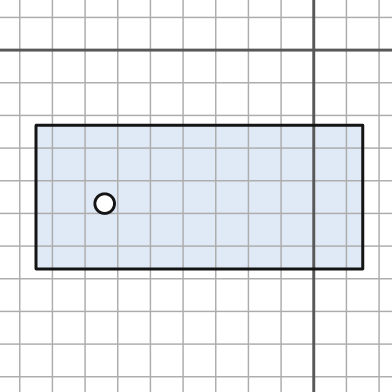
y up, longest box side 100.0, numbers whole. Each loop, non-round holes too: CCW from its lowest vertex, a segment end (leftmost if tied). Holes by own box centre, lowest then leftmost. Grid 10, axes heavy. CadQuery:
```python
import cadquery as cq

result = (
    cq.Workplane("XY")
    .moveTo(-85.0, -67.0)
    .lineTo(15.0, -67.0)
    .lineTo(15.0, -23.0)
    .lineTo(-85.0, -23.0)
    .close()
    .moveTo(-64.0, -47.0)
    .circle(3.0)
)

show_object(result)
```